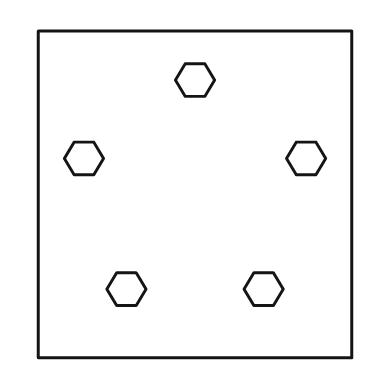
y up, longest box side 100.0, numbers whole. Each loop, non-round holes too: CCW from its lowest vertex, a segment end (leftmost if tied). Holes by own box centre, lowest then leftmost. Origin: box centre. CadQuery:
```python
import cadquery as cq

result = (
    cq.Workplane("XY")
    .moveTo(-48.0, -50.0)
    .lineTo(48.0, -50.0)
    .lineTo(48.0, 50.0)
    .lineTo(-48.0, 50.0)
    .close()
    .moveTo(-24.0, -34.0)
    .lineTo(-18.0, -34.0)
    .lineTo(-15.0, -29.0)
    .lineTo(-18.0, -24.0)
    .lineTo(-24.0, -24.0)
    .lineTo(-27.0, -29.0)
    .close()
    .moveTo(18.0, -34.0)
    .lineTo(24.0, -34.0)
    .lineTo(27.0, -29.0)
    .lineTo(24.0, -24.0)
    .lineTo(18.0, -24.0)
    .lineTo(15.0, -29.0)
    .close()
    .moveTo(-37.0, 6.0)
    .lineTo(-31.0, 6.0)
    .lineTo(-28.0, 11.0)
    .lineTo(-31.0, 16.0)
    .lineTo(-37.0, 16.0)
    .lineTo(-40.0, 11.0)
    .close()
    .moveTo(31.0, 6.0)
    .lineTo(37.0, 6.0)
    .lineTo(40.0, 11.0)
    .lineTo(37.0, 16.0)
    .lineTo(31.0, 16.0)
    .lineTo(28.0, 11.0)
    .close()
    .moveTo(-3.0, 30.0)
    .lineTo(3.0, 30.0)
    .lineTo(6.0, 35.0)
    .lineTo(3.0, 40.0)
    .lineTo(-3.0, 40.0)
    .lineTo(-6.0, 35.0)
    .close()
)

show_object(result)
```